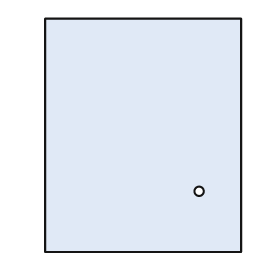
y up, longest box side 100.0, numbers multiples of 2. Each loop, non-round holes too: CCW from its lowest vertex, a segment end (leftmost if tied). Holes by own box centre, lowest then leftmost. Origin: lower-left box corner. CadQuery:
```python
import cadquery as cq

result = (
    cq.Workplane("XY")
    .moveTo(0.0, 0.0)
    .lineTo(84.0, 0.0)
    .lineTo(84.0, 100.0)
    .lineTo(0.0, 100.0)
    .close()
    .moveTo(66.0, 26.0)
    .circle(2.0)
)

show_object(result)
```